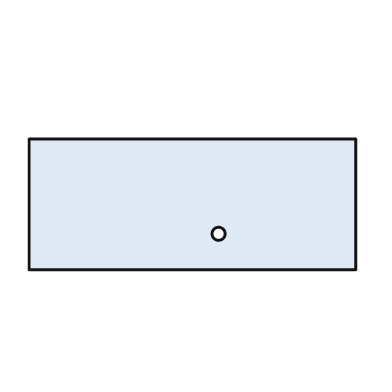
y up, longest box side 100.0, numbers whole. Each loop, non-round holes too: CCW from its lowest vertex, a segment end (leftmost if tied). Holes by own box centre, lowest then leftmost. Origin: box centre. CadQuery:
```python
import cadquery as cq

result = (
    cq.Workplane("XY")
    .moveTo(-50.0, -20.0)
    .lineTo(50.0, -20.0)
    .lineTo(50.0, 20.0)
    .lineTo(-50.0, 20.0)
    .close()
    .moveTo(8.0, -9.0)
    .circle(2.0)
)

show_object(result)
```